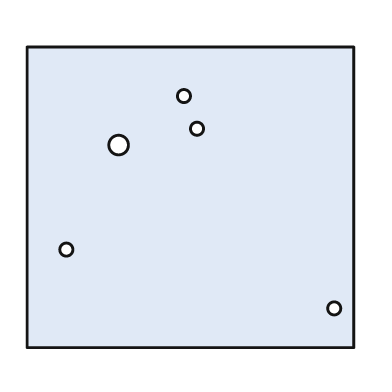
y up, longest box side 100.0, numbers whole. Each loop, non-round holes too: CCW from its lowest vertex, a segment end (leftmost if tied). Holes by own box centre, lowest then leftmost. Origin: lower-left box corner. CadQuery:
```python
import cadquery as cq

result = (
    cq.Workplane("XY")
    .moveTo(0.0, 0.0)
    .lineTo(100.0, 0.0)
    .lineTo(100.0, 92.0)
    .lineTo(0.0, 92.0)
    .close()
    .moveTo(94.0, 12.0)
    .circle(2.0)
    .moveTo(12.0, 30.0)
    .circle(2.0)
    .moveTo(28.0, 62.0)
    .circle(3.0)
    .moveTo(52.0, 67.0)
    .circle(2.0)
    .moveTo(48.0, 77.0)
    .circle(2.0)
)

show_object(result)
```